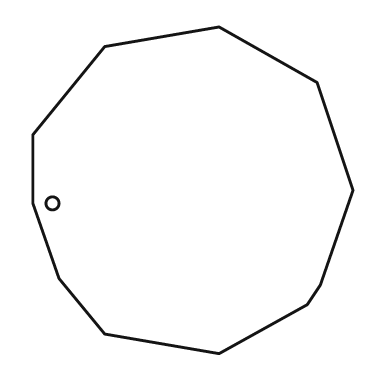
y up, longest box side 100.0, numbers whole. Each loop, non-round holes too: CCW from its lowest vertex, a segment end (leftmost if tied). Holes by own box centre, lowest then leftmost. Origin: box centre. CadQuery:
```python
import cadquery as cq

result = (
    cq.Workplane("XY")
    .moveTo(8.0, -50.0)
    .lineTo(35.0, -35.0)
    .lineTo(39.0, -29.0)
    .lineTo(49.0, 0.0)
    .lineTo(38.0, 33.0)
    .lineTo(8.0, 50.0)
    .lineTo(-27.0, 44.0)
    .lineTo(-49.0, 17.0)
    .lineTo(-49.0, -4.0)
    .lineTo(-41.0, -27.0)
    .lineTo(-27.0, -44.0)
    .close()
    .moveTo(-43.0, -4.0)
    .circle(2.0)
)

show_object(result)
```